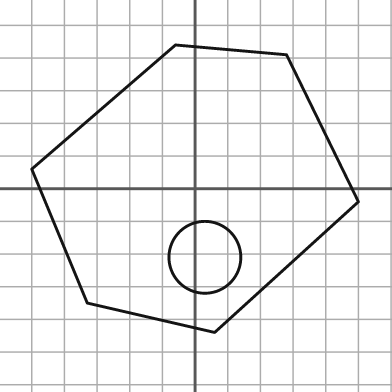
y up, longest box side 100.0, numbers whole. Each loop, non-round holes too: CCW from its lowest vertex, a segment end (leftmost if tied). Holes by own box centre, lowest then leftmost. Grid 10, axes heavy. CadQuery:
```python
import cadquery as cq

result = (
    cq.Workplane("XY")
    .moveTo(6.0, -44.0)
    .lineTo(50.0, -4.0)
    .lineTo(28.0, 41.0)
    .lineTo(-6.0, 44.0)
    .lineTo(-50.0, 6.0)
    .lineTo(-33.0, -35.0)
    .close()
    .moveTo(3.0, -21.0)
    .circle(11.0)
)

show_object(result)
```